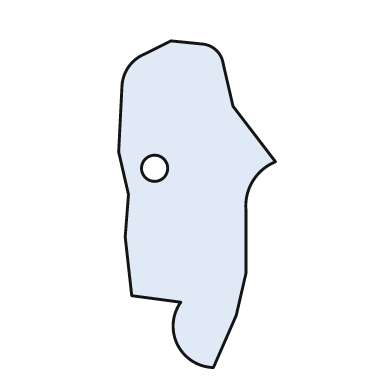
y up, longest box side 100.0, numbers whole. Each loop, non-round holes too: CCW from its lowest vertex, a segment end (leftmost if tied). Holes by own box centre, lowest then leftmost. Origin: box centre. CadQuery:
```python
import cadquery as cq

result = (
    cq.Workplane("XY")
    .moveTo(5.0, -50.0)
    .lineTo(12.0, -34.0)
    .lineTo(15.0, -21.0)
    .lineTo(15.0, -2.0)
    .threePointArc((17.0, 7.0), (24.0, 13.0))
    .lineTo(11.0, 30.0)
    .lineTo(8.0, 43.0)
    .threePointArc((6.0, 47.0), (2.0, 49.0))
    .lineTo(-8.0, 50.0)
    .lineTo(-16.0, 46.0)
    .threePointArc((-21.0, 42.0), (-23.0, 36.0))
    .lineTo(-24.0, 16.0)
    .lineTo(-21.0, 3.0)
    .lineTo(-22.0, -10.0)
    .lineTo(-20.0, -28.0)
    .lineTo(-5.0, -30.0)
    .threePointArc((-6.0, -43.0), (5.0, -50.0))
    .close()
    .moveTo(-13.0, 11.0)
    .circle(4.0)
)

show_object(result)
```